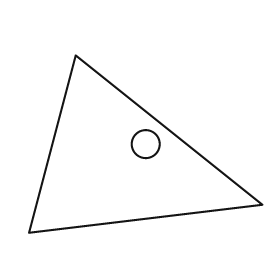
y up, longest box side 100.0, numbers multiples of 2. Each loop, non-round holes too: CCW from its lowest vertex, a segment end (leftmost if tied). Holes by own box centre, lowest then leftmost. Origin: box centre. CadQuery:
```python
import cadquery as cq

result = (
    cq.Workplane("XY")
    .moveTo(-50.0, -38.0)
    .lineTo(50.0, -26.0)
    .lineTo(-30.0, 38.0)
    .close()
    .moveTo(0.0, 0.0)
    .circle(6.0)
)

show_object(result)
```